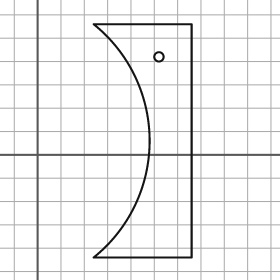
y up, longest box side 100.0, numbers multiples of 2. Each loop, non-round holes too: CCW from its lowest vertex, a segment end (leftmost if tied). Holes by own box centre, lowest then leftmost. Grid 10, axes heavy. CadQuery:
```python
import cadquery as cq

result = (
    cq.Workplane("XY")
    .moveTo(24.0, -44.0)
    .lineTo(66.0, -44.0)
    .lineTo(66.0, 56.0)
    .lineTo(24.0, 56.0)
    .threePointArc((48.0, 6.0), (24.0, -44.0))
    .close()
    .moveTo(52.0, 42.0)
    .circle(2.0)
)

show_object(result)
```